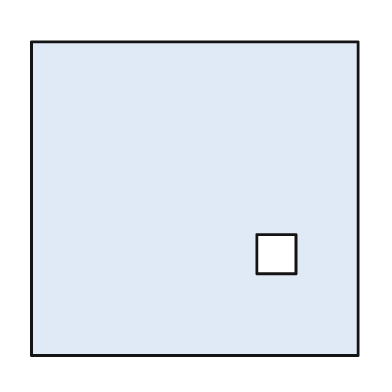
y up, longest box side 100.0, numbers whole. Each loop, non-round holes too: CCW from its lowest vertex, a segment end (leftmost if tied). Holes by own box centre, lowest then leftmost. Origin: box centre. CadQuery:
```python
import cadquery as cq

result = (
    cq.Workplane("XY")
    .moveTo(-50.0, -48.0)
    .lineTo(50.0, -48.0)
    .lineTo(50.0, 48.0)
    .lineTo(-50.0, 48.0)
    .close()
    .moveTo(19.0, -23.0)
    .lineTo(31.0, -23.0)
    .lineTo(31.0, -11.0)
    .lineTo(19.0, -11.0)
    .close()
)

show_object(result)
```